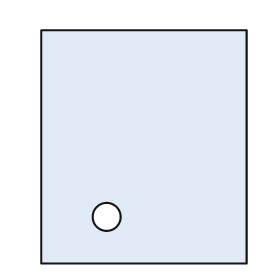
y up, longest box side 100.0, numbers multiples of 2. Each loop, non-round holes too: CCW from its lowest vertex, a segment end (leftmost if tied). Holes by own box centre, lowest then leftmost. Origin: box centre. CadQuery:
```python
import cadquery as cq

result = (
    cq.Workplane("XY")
    .moveTo(-44.0, -50.0)
    .lineTo(44.0, -50.0)
    .lineTo(44.0, 50.0)
    .lineTo(-44.0, 50.0)
    .close()
    .moveTo(-16.0, -30.0)
    .circle(6.0)
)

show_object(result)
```